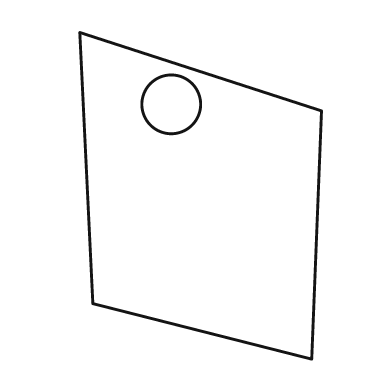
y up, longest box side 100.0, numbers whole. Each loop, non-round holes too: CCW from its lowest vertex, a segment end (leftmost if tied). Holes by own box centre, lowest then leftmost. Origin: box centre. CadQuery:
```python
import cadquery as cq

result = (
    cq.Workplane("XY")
    .moveTo(34.0, -50.0)
    .lineTo(37.0, 26.0)
    .lineTo(-37.0, 50.0)
    .lineTo(-33.0, -33.0)
    .close()
    .moveTo(-9.0, 28.0)
    .circle(9.0)
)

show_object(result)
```